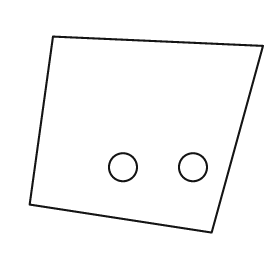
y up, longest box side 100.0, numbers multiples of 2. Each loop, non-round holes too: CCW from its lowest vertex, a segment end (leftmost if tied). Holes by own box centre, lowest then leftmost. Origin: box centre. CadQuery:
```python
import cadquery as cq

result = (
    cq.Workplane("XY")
    .moveTo(28.0, -42.0)
    .lineTo(50.0, 38.0)
    .lineTo(-40.0, 42.0)
    .lineTo(-50.0, -30.0)
    .close()
    .moveTo(-10.0, -14.0)
    .circle(6.0)
    .moveTo(20.0, -14.0)
    .circle(6.0)
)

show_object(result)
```